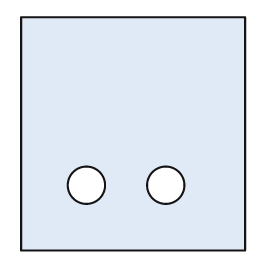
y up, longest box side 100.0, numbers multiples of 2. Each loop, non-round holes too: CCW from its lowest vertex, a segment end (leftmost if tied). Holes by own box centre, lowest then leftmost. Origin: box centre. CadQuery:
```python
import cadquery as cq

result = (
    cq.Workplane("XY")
    .moveTo(-48.0, -50.0)
    .lineTo(48.0, -50.0)
    .lineTo(48.0, 50.0)
    .lineTo(-48.0, 50.0)
    .close()
    .moveTo(-20.0, -22.0)
    .circle(8.0)
    .moveTo(14.0, -22.0)
    .circle(8.0)
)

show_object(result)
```